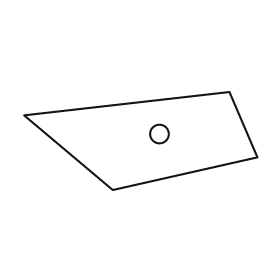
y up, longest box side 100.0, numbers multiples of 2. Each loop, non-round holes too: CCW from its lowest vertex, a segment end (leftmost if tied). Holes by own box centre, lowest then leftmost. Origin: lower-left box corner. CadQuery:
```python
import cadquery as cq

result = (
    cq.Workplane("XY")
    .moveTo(38.0, 0.0)
    .lineTo(100.0, 14.0)
    .lineTo(88.0, 42.0)
    .lineTo(0.0, 32.0)
    .close()
    .moveTo(58.0, 24.0)
    .circle(4.0)
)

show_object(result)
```